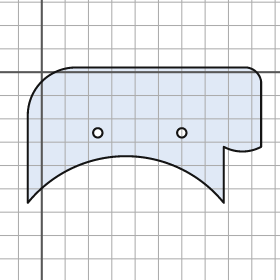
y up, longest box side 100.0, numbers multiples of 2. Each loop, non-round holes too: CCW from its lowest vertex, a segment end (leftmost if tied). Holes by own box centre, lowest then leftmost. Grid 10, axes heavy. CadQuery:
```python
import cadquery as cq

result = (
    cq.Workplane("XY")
    .moveTo(-6.0, -56.0)
    .threePointArc((36.0, -36.0), (78.0, -56.0))
    .lineTo(78.0, -32.0)
    .threePointArc((86.0, -34.0), (94.0, -32.0))
    .lineTo(94.0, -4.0)
    .threePointArc((92.0, 0.0), (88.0, 2.0))
    .lineTo(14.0, 2.0)
    .threePointArc((0.0, -4.0), (-6.0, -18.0))
    .close()
    .moveTo(24.0, -26.0)
    .circle(2.0)
    .moveTo(60.0, -26.0)
    .circle(2.0)
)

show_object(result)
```